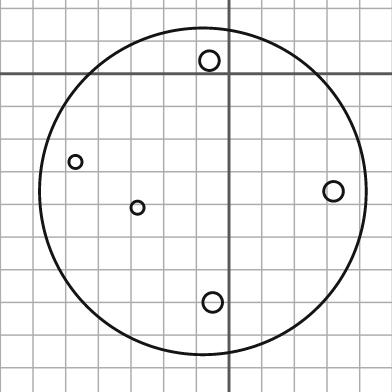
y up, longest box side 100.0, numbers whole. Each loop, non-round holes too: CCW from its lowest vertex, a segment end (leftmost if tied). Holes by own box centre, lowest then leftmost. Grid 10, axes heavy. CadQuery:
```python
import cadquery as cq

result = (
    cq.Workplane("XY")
    .moveTo(-8.0, -36.0)
    .circle(50.0)
    .moveTo(-5.0, -70.0)
    .circle(3.0)
    .moveTo(-28.0, -41.0)
    .circle(2.0)
    .moveTo(32.0, -36.0)
    .circle(3.0)
    .moveTo(-47.0, -27.0)
    .circle(2.0)
    .moveTo(-6.0, 4.0)
    .circle(3.0)
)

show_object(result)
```